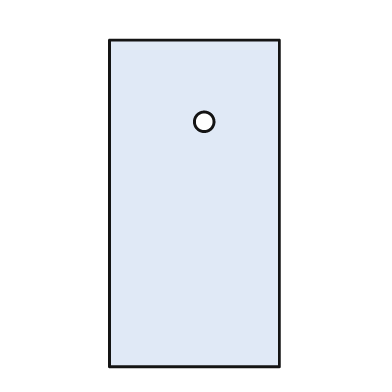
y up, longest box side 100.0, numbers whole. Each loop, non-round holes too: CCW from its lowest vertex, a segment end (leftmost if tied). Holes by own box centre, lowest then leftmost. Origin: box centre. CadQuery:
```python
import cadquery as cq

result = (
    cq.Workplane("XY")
    .moveTo(-26.0, -50.0)
    .lineTo(26.0, -50.0)
    .lineTo(26.0, 50.0)
    .lineTo(-26.0, 50.0)
    .close()
    .moveTo(3.0, 25.0)
    .circle(3.0)
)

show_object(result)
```